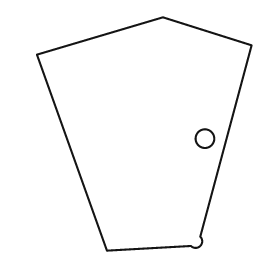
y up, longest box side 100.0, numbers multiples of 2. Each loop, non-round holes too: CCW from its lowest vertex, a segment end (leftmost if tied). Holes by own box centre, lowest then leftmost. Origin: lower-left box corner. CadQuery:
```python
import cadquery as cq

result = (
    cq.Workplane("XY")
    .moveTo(30.0, 0.0)
    .lineTo(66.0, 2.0)
    .threePointArc((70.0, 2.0), (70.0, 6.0))
    .lineTo(92.0, 88.0)
    .lineTo(54.0, 100.0)
    .lineTo(0.0, 84.0)
    .close()
    .moveTo(72.0, 48.0)
    .circle(4.0)
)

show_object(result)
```